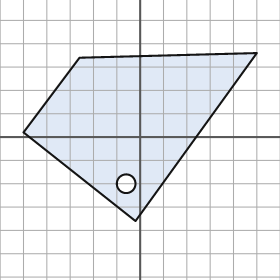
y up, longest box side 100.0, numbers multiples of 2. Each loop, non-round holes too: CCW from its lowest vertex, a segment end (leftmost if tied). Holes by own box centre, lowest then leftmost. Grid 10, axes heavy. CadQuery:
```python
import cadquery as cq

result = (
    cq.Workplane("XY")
    .moveTo(-2.0, -36.0)
    .lineTo(50.0, 36.0)
    .lineTo(-26.0, 34.0)
    .lineTo(-50.0, 2.0)
    .close()
    .moveTo(-6.0, -20.0)
    .circle(4.0)
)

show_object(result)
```